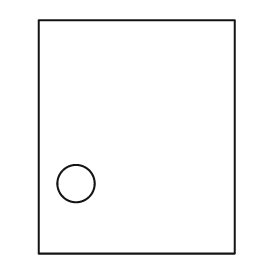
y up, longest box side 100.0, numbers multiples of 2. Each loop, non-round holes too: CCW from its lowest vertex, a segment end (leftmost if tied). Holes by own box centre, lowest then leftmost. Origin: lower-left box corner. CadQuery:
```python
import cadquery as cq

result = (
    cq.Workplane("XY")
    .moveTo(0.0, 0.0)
    .lineTo(84.0, 0.0)
    .lineTo(84.0, 100.0)
    .lineTo(0.0, 100.0)
    .close()
    .moveTo(16.0, 30.0)
    .circle(8.0)
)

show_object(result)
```